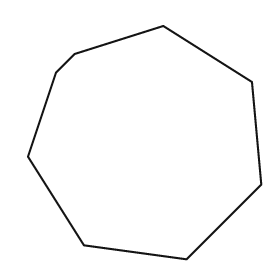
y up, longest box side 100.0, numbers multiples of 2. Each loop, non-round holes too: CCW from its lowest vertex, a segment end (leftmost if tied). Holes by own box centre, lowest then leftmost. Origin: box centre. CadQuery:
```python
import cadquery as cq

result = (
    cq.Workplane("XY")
    .moveTo(18.0, -50.0)
    .lineTo(50.0, -18.0)
    .lineTo(46.0, 26.0)
    .lineTo(8.0, 50.0)
    .lineTo(-30.0, 38.0)
    .lineTo(-38.0, 30.0)
    .lineTo(-50.0, -6.0)
    .lineTo(-26.0, -44.0)
    .close()
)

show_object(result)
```